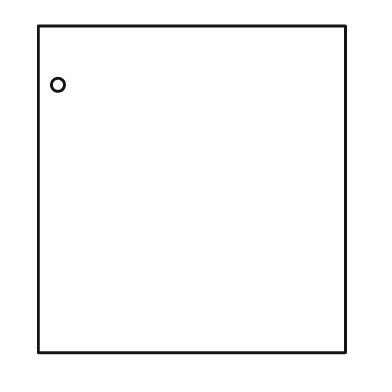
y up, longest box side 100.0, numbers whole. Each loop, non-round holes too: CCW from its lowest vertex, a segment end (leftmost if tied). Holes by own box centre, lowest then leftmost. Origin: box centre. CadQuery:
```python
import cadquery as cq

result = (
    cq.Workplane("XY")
    .moveTo(-47.0, -50.0)
    .lineTo(47.0, -50.0)
    .lineTo(47.0, 50.0)
    .lineTo(-47.0, 50.0)
    .close()
    .moveTo(-41.0, 32.0)
    .circle(2.0)
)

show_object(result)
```